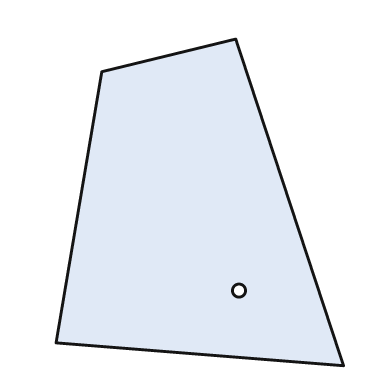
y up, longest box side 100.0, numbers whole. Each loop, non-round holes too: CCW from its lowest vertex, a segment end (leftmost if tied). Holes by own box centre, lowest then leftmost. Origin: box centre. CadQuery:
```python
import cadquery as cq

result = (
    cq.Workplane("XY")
    .moveTo(44.0, -50.0)
    .lineTo(11.0, 50.0)
    .lineTo(-30.0, 40.0)
    .lineTo(-44.0, -43.0)
    .close()
    .moveTo(12.0, -27.0)
    .circle(2.0)
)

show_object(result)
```